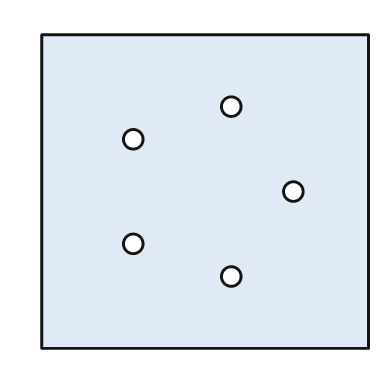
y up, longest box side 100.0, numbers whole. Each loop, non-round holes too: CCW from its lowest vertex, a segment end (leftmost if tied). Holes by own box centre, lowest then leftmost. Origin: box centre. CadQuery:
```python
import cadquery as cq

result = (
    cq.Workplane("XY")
    .moveTo(-50.0, -48.0)
    .lineTo(50.0, -48.0)
    .lineTo(50.0, 48.0)
    .lineTo(-50.0, 48.0)
    .close()
    .moveTo(8.0, -26.0)
    .circle(3.0)
    .moveTo(-22.0, -16.0)
    .circle(3.0)
    .moveTo(27.0, 0.0)
    .circle(3.0)
    .moveTo(-22.0, 16.0)
    .circle(3.0)
    .moveTo(8.0, 26.0)
    .circle(3.0)
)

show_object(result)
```